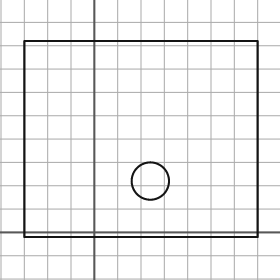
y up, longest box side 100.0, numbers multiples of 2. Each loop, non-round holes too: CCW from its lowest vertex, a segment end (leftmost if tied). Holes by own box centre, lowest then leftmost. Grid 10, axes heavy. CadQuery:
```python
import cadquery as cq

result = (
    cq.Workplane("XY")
    .moveTo(-30.0, -2.0)
    .lineTo(70.0, -2.0)
    .lineTo(70.0, 82.0)
    .lineTo(-30.0, 82.0)
    .close()
    .moveTo(24.0, 22.0)
    .circle(8.0)
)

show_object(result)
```